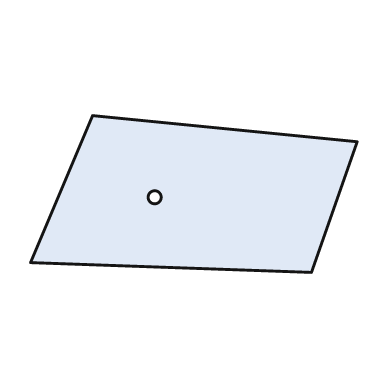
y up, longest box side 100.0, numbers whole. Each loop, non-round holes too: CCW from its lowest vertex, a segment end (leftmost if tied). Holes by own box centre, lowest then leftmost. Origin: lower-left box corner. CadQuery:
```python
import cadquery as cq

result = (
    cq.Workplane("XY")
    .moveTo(86.0, 0.0)
    .lineTo(100.0, 40.0)
    .lineTo(19.0, 48.0)
    .lineTo(0.0, 3.0)
    .close()
    .moveTo(38.0, 23.0)
    .circle(2.0)
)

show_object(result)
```